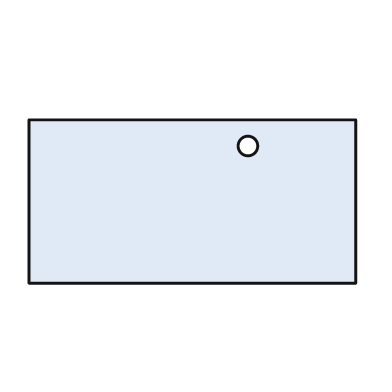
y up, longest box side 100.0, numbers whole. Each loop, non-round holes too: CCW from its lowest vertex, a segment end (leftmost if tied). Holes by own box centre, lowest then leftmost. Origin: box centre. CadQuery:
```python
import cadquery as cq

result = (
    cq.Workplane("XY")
    .moveTo(-50.0, -25.0)
    .lineTo(50.0, -25.0)
    .lineTo(50.0, 25.0)
    .lineTo(-50.0, 25.0)
    .close()
    .moveTo(17.0, 17.0)
    .circle(3.0)
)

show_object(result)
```